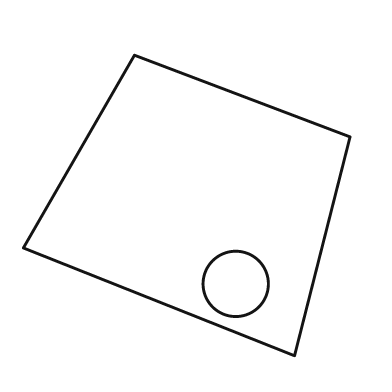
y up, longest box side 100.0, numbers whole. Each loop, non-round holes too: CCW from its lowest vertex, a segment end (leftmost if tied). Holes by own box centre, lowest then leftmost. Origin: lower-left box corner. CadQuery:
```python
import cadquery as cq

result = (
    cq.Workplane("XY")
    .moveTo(83.0, 0.0)
    .lineTo(100.0, 67.0)
    .lineTo(34.0, 92.0)
    .lineTo(0.0, 33.0)
    .close()
    .moveTo(65.0, 22.0)
    .circle(10.0)
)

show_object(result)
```